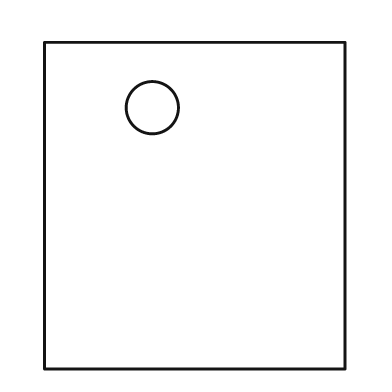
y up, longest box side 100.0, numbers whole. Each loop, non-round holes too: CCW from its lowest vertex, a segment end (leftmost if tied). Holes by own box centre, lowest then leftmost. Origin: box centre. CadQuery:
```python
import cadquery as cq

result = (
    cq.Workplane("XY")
    .moveTo(-46.0, -50.0)
    .lineTo(46.0, -50.0)
    .lineTo(46.0, 50.0)
    .lineTo(-46.0, 50.0)
    .close()
    .moveTo(-13.0, 30.0)
    .circle(8.0)
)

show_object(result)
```